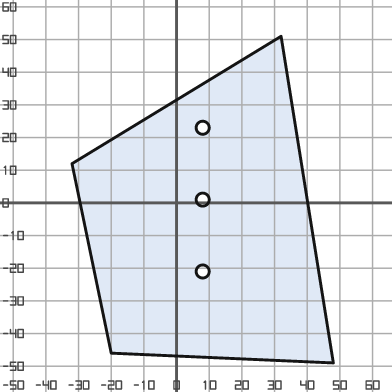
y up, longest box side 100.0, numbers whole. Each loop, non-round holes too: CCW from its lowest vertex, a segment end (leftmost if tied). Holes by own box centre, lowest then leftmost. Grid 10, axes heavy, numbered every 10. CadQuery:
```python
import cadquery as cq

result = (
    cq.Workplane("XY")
    .moveTo(48.0, -49.0)
    .lineTo(32.0, 51.0)
    .lineTo(-32.0, 12.0)
    .lineTo(-20.0, -46.0)
    .close()
    .moveTo(8.0, -21.0)
    .circle(2.0)
    .moveTo(8.0, 1.0)
    .circle(2.0)
    .moveTo(8.0, 23.0)
    .circle(2.0)
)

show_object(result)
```